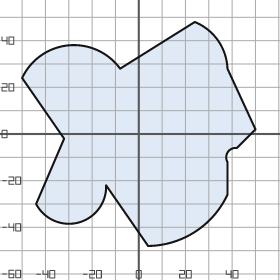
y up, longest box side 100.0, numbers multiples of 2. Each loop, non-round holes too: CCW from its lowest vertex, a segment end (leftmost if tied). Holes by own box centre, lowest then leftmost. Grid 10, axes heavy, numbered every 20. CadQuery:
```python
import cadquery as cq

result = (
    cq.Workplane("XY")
    .moveTo(4.0, -48.0)
    .threePointArc((24.0, -42.0), (38.0, -26.0))
    .lineTo(38.0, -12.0)
    .threePointArc((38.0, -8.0), (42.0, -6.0))
    .lineTo(50.0, 2.0)
    .lineTo(38.0, 28.0)
    .threePointArc((34.0, 40.0), (24.0, 48.0))
    .lineTo(-8.0, 28.0)
    .threePointArc((-30.0, 38.0), (-50.0, 24.0))
    .lineTo(-32.0, -2.0)
    .lineTo(-44.0, -30.0)
    .threePointArc((-26.0, -38.0), (-14.0, -22.0))
    .close()
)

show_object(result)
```